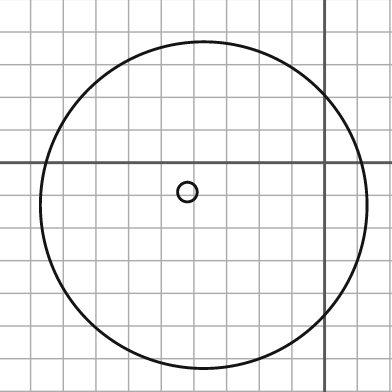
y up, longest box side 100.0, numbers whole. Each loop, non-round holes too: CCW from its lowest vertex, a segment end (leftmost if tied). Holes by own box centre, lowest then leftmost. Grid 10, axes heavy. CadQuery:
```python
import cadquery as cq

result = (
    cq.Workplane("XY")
    .moveTo(-37.0, -13.0)
    .circle(50.0)
    .moveTo(-42.0, -9.0)
    .circle(3.0)
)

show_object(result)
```